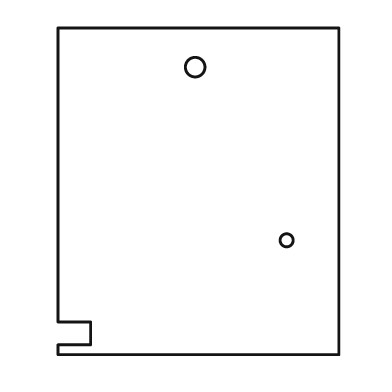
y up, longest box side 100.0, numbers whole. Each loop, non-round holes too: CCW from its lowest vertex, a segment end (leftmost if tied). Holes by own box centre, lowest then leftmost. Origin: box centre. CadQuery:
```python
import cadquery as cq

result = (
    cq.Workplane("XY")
    .moveTo(-43.0, -50.0)
    .lineTo(43.0, -50.0)
    .lineTo(43.0, 50.0)
    .lineTo(-43.0, 50.0)
    .lineTo(-43.0, -40.0)
    .lineTo(-33.0, -40.0)
    .lineTo(-33.0, -47.0)
    .lineTo(-43.0, -47.0)
    .close()
    .moveTo(27.0, -15.0)
    .circle(2.0)
    .moveTo(-1.0, 38.0)
    .circle(3.0)
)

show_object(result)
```